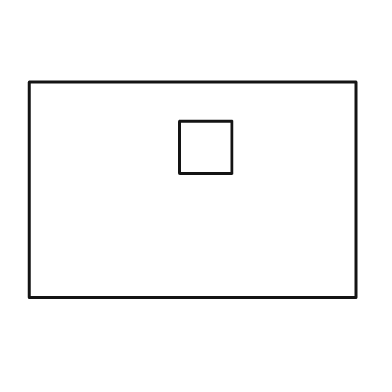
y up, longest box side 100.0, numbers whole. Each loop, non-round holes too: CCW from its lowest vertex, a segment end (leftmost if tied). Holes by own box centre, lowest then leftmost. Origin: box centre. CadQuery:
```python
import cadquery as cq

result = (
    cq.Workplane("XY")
    .moveTo(-50.0, -33.0)
    .lineTo(50.0, -33.0)
    .lineTo(50.0, 33.0)
    .lineTo(-50.0, 33.0)
    .close()
    .moveTo(-4.0, 5.0)
    .lineTo(12.0, 5.0)
    .lineTo(12.0, 21.0)
    .lineTo(-4.0, 21.0)
    .close()
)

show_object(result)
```